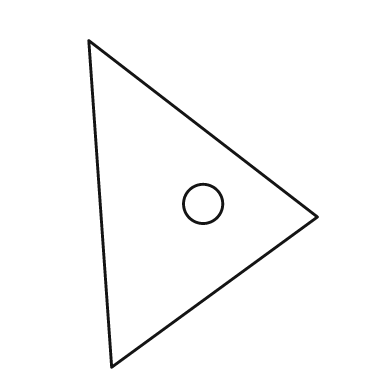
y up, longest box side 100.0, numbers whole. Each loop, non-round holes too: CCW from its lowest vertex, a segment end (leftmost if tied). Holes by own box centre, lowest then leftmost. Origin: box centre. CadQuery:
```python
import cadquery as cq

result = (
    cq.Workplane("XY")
    .moveTo(-28.0, -50.0)
    .lineTo(35.0, -4.0)
    .lineTo(-35.0, 50.0)
    .close()
    .moveTo(0.0, 0.0)
    .circle(6.0)
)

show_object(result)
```